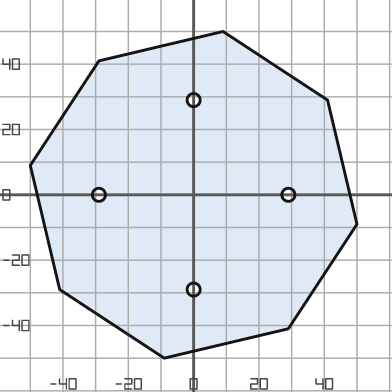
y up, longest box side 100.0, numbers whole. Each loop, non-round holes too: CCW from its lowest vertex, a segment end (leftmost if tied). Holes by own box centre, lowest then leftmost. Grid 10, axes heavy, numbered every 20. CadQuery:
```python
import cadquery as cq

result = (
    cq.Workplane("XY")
    .moveTo(-9.0, -50.0)
    .lineTo(29.0, -41.0)
    .lineTo(50.0, -9.0)
    .lineTo(41.0, 29.0)
    .lineTo(9.0, 50.0)
    .lineTo(-29.0, 41.0)
    .lineTo(-50.0, 9.0)
    .lineTo(-41.0, -29.0)
    .close()
    .moveTo(0.0, -29.0)
    .circle(2.0)
    .moveTo(-29.0, 0.0)
    .circle(2.0)
    .moveTo(29.0, 0.0)
    .circle(2.0)
    .moveTo(0.0, 29.0)
    .circle(2.0)
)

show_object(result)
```